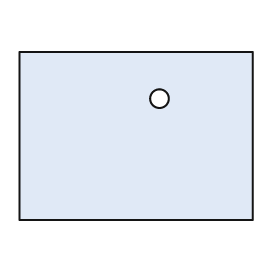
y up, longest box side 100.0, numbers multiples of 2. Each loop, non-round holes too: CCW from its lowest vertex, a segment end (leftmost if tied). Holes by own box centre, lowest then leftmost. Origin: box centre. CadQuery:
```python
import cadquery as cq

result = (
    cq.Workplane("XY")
    .moveTo(-50.0, -36.0)
    .lineTo(50.0, -36.0)
    .lineTo(50.0, 36.0)
    .lineTo(-50.0, 36.0)
    .close()
    .moveTo(10.0, 16.0)
    .circle(4.0)
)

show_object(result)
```